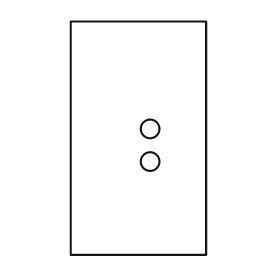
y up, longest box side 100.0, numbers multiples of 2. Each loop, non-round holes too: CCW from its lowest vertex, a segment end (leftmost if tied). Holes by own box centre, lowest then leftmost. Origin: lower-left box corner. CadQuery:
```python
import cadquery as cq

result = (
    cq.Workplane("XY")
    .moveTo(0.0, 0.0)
    .lineTo(58.0, 0.0)
    .lineTo(58.0, 100.0)
    .lineTo(0.0, 100.0)
    .close()
    .moveTo(34.0, 40.0)
    .circle(4.0)
    .moveTo(34.0, 54.0)
    .circle(4.0)
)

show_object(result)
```